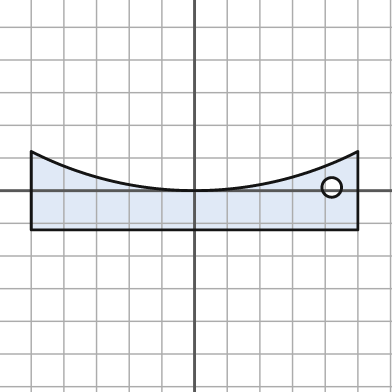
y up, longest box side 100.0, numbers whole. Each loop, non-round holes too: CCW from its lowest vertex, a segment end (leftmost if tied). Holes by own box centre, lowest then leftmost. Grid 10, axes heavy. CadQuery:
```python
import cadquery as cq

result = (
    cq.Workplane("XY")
    .moveTo(-50.0, -12.0)
    .lineTo(50.0, -12.0)
    .lineTo(50.0, 12.0)
    .threePointArc((0.0, 0.0), (-50.0, 12.0))
    .close()
    .moveTo(42.0, 1.0)
    .circle(3.0)
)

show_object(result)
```